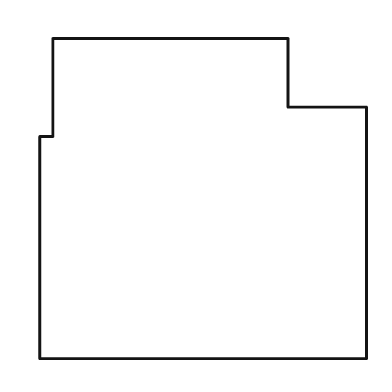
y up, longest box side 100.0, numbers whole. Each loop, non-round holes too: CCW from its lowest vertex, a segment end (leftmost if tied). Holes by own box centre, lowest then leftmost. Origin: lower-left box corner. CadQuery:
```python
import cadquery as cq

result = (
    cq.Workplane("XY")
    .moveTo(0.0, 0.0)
    .lineTo(100.0, 0.0)
    .lineTo(100.0, 77.0)
    .lineTo(76.0, 77.0)
    .lineTo(76.0, 98.0)
    .lineTo(4.0, 98.0)
    .lineTo(4.0, 68.0)
    .lineTo(0.0, 68.0)
    .close()
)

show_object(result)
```